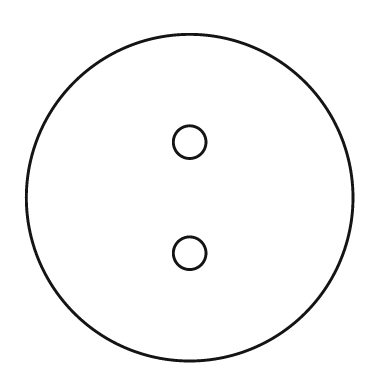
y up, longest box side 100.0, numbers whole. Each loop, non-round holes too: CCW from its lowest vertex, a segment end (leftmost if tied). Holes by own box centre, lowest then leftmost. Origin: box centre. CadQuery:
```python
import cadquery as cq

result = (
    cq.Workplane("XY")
    .moveTo(0.0, 0.0)
    .circle(50.0)
    .moveTo(0.0, -17.0)
    .circle(5.0)
    .moveTo(0.0, 17.0)
    .circle(5.0)
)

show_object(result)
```